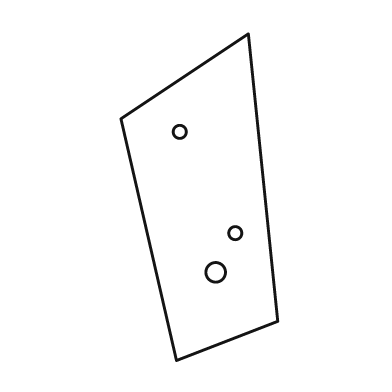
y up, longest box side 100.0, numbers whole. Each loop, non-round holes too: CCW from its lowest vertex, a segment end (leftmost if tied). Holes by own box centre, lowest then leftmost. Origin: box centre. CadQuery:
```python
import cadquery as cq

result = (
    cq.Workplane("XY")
    .moveTo(-7.0, -50.0)
    .lineTo(24.0, -38.0)
    .lineTo(15.0, 50.0)
    .lineTo(-24.0, 24.0)
    .close()
    .moveTo(5.0, -23.0)
    .circle(3.0)
    .moveTo(11.0, -11.0)
    .circle(2.0)
    .moveTo(-6.0, 20.0)
    .circle(2.0)
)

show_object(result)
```